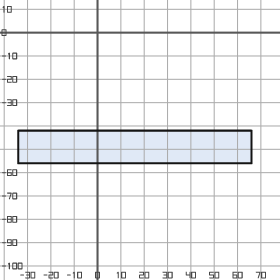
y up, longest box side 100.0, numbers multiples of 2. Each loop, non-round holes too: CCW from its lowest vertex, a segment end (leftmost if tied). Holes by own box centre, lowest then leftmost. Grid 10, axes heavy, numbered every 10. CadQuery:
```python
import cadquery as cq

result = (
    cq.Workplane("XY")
    .moveTo(-34.0, -56.0)
    .lineTo(66.0, -56.0)
    .lineTo(66.0, -42.0)
    .lineTo(-34.0, -42.0)
    .close()
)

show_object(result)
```